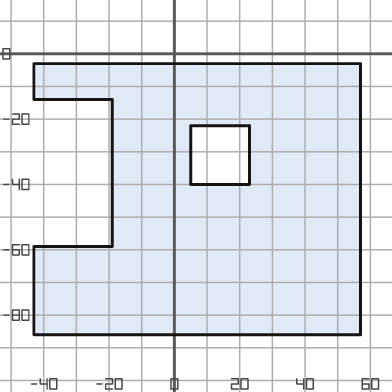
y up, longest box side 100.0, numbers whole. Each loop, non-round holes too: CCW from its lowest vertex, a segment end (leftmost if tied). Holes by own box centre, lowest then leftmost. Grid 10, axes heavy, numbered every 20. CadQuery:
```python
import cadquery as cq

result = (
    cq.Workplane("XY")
    .moveTo(-43.0, -86.0)
    .lineTo(57.0, -86.0)
    .lineTo(57.0, -3.0)
    .lineTo(-43.0, -3.0)
    .lineTo(-43.0, -14.0)
    .lineTo(-19.0, -14.0)
    .lineTo(-19.0, -59.0)
    .lineTo(-43.0, -59.0)
    .close()
    .moveTo(5.0, -40.0)
    .lineTo(23.0, -40.0)
    .lineTo(23.0, -22.0)
    .lineTo(5.0, -22.0)
    .close()
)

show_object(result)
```